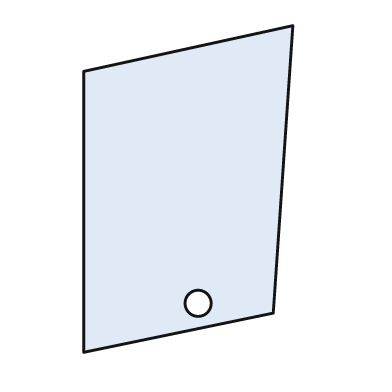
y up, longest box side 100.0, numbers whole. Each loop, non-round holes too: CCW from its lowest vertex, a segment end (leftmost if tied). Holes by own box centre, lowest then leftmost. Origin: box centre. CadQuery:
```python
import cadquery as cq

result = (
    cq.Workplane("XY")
    .moveTo(-32.0, -50.0)
    .lineTo(26.0, -38.0)
    .lineTo(32.0, 50.0)
    .lineTo(-32.0, 36.0)
    .close()
    .moveTo(3.0, -35.0)
    .circle(4.0)
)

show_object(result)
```